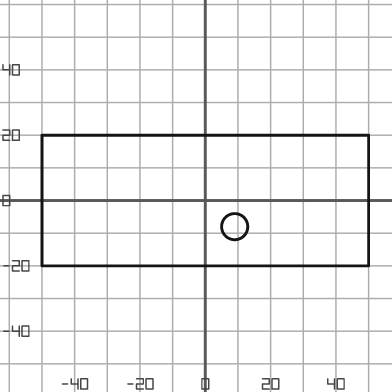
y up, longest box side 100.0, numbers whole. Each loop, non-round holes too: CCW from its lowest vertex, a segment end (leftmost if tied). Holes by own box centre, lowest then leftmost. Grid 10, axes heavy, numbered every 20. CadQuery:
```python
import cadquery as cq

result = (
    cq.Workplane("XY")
    .moveTo(-50.0, -20.0)
    .lineTo(50.0, -20.0)
    .lineTo(50.0, 20.0)
    .lineTo(-50.0, 20.0)
    .close()
    .moveTo(9.0, -8.0)
    .circle(4.0)
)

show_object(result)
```